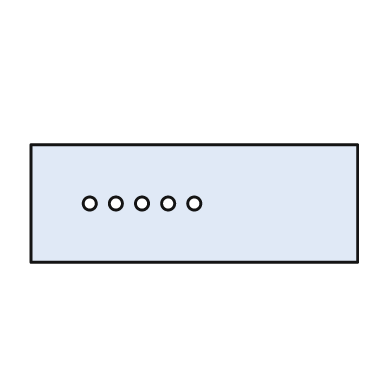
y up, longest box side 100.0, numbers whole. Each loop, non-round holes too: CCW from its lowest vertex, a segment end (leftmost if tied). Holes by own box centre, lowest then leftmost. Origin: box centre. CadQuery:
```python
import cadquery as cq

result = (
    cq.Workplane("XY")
    .moveTo(-50.0, -18.0)
    .lineTo(50.0, -18.0)
    .lineTo(50.0, 18.0)
    .lineTo(-50.0, 18.0)
    .close()
    .moveTo(-32.0, 0.0)
    .circle(2.0)
    .moveTo(-24.0, 0.0)
    .circle(2.0)
    .moveTo(-16.0, 0.0)
    .circle(2.0)
    .moveTo(-8.0, 0.0)
    .circle(2.0)
    .moveTo(0.0, 0.0)
    .circle(2.0)
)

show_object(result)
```